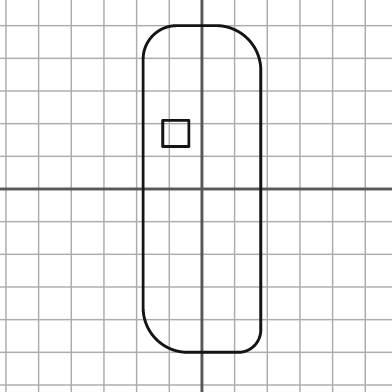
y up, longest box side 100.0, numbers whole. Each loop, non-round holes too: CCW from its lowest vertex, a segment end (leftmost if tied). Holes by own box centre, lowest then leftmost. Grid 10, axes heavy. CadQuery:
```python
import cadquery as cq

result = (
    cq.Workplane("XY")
    .moveTo(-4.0, -50.0)
    .lineTo(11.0, -50.0)
    .threePointArc((16.0, -48.0), (18.0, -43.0))
    .lineTo(18.0, 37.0)
    .threePointArc((14.0, 46.0), (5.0, 50.0))
    .lineTo(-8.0, 50.0)
    .threePointArc((-15.0, 47.0), (-18.0, 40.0))
    .lineTo(-18.0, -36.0)
    .threePointArc((-14.0, -46.0), (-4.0, -50.0))
    .close()
    .moveTo(-12.0, 13.0)
    .lineTo(-4.0, 13.0)
    .lineTo(-4.0, 21.0)
    .lineTo(-12.0, 21.0)
    .close()
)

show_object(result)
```